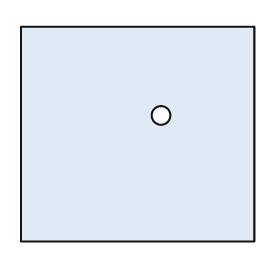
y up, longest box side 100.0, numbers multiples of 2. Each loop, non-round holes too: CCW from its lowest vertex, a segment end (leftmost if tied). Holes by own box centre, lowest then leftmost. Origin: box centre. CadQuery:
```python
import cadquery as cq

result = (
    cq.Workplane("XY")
    .moveTo(-50.0, -46.0)
    .lineTo(50.0, -46.0)
    .lineTo(50.0, 46.0)
    .lineTo(-50.0, 46.0)
    .close()
    .moveTo(10.0, 8.0)
    .circle(4.0)
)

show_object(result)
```